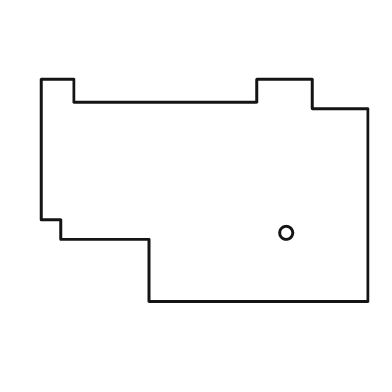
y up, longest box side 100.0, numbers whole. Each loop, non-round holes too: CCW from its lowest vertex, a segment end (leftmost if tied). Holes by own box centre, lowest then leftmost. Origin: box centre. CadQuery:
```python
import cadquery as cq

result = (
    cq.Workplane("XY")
    .moveTo(-17.0, -34.0)
    .lineTo(50.0, -34.0)
    .lineTo(50.0, 25.0)
    .lineTo(33.0, 25.0)
    .lineTo(33.0, 34.0)
    .lineTo(16.0, 34.0)
    .lineTo(16.0, 27.0)
    .lineTo(-40.0, 27.0)
    .lineTo(-40.0, 34.0)
    .lineTo(-50.0, 34.0)
    .lineTo(-50.0, -9.0)
    .lineTo(-44.0, -9.0)
    .lineTo(-44.0, -15.0)
    .lineTo(-17.0, -15.0)
    .close()
    .moveTo(25.0, -13.0)
    .circle(2.0)
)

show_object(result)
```